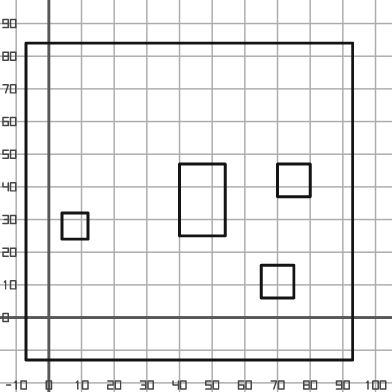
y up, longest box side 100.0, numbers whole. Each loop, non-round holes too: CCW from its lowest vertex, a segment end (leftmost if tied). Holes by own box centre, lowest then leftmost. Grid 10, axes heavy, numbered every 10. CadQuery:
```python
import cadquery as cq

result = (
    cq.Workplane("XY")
    .moveTo(-7.0, -13.0)
    .lineTo(93.0, -13.0)
    .lineTo(93.0, 84.0)
    .lineTo(-7.0, 84.0)
    .close()
    .moveTo(65.0, 6.0)
    .lineTo(75.0, 6.0)
    .lineTo(75.0, 16.0)
    .lineTo(65.0, 16.0)
    .close()
    .moveTo(4.0, 24.0)
    .lineTo(12.0, 24.0)
    .lineTo(12.0, 32.0)
    .lineTo(4.0, 32.0)
    .close()
    .moveTo(40.0, 25.0)
    .lineTo(54.0, 25.0)
    .lineTo(54.0, 47.0)
    .lineTo(40.0, 47.0)
    .close()
    .moveTo(70.0, 37.0)
    .lineTo(80.0, 37.0)
    .lineTo(80.0, 47.0)
    .lineTo(70.0, 47.0)
    .close()
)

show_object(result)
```